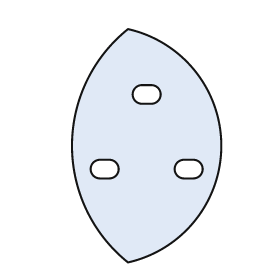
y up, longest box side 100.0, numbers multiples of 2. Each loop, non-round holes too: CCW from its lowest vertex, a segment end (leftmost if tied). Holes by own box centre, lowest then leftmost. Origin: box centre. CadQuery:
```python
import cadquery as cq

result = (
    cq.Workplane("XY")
    .moveTo(-8.0, -50.0)
    .threePointArc((32.0, 0.0), (-8.0, 50.0))
    .threePointArc((-32.0, 0.0), (-8.0, -50.0))
    .close()
    .moveTo(-20.0, -14.0)
    .lineTo(-16.0, -14.0)
    .threePointArc((-12.0, -10.0), (-16.0, -6.0))
    .lineTo(-20.0, -6.0)
    .threePointArc((-24.0, -10.0), (-20.0, -14.0))
    .close()
    .moveTo(16.0, -14.0)
    .lineTo(20.0, -14.0)
    .threePointArc((24.0, -10.0), (20.0, -6.0))
    .lineTo(16.0, -6.0)
    .threePointArc((12.0, -10.0), (16.0, -14.0))
    .close()
    .moveTo(-2.0, 18.0)
    .lineTo(2.0, 18.0)
    .threePointArc((6.0, 22.0), (2.0, 26.0))
    .lineTo(-2.0, 26.0)
    .threePointArc((-6.0, 22.0), (-2.0, 18.0))
    .close()
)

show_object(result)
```